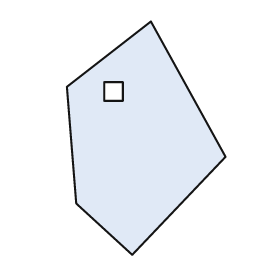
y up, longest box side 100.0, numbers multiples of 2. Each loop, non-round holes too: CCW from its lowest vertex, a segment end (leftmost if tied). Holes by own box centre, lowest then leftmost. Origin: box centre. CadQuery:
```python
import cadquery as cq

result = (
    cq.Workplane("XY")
    .moveTo(-6.0, -50.0)
    .lineTo(34.0, -8.0)
    .lineTo(2.0, 50.0)
    .lineTo(-34.0, 22.0)
    .lineTo(-30.0, -28.0)
    .close()
    .moveTo(-18.0, 16.0)
    .lineTo(-10.0, 16.0)
    .lineTo(-10.0, 24.0)
    .lineTo(-18.0, 24.0)
    .close()
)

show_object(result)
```